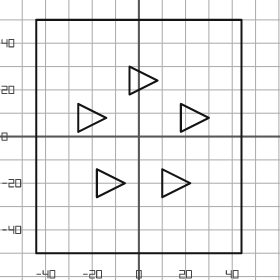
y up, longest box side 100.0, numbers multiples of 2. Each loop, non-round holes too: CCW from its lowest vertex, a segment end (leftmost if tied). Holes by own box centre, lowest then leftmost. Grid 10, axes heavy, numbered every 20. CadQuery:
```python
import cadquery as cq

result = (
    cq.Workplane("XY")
    .moveTo(-44.0, -50.0)
    .lineTo(44.0, -50.0)
    .lineTo(44.0, 50.0)
    .lineTo(-44.0, 50.0)
    .close()
    .moveTo(-18.0, -26.0)
    .lineTo(-6.0, -20.0)
    .lineTo(-18.0, -14.0)
    .close()
    .moveTo(10.0, -26.0)
    .lineTo(22.0, -20.0)
    .lineTo(10.0, -14.0)
    .close()
    .moveTo(-26.0, 2.0)
    .lineTo(-14.0, 8.0)
    .lineTo(-26.0, 14.0)
    .close()
    .moveTo(18.0, 2.0)
    .lineTo(30.0, 8.0)
    .lineTo(18.0, 14.0)
    .close()
    .moveTo(-4.0, 18.0)
    .lineTo(8.0, 24.0)
    .lineTo(-4.0, 30.0)
    .close()
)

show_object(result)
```